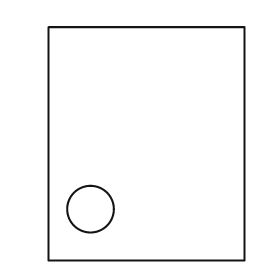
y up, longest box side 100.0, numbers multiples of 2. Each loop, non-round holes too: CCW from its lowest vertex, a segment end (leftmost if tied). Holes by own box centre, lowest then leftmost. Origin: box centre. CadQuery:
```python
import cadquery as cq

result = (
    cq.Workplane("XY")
    .moveTo(-42.0, -50.0)
    .lineTo(42.0, -50.0)
    .lineTo(42.0, 50.0)
    .lineTo(-42.0, 50.0)
    .close()
    .moveTo(-24.0, -28.0)
    .circle(10.0)
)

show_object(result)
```